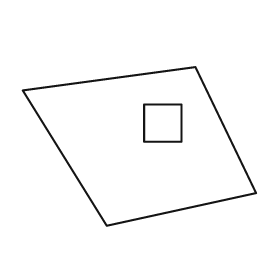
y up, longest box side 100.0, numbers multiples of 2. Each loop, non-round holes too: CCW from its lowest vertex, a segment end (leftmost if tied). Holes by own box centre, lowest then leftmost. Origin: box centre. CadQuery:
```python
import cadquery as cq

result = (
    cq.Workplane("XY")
    .moveTo(-14.0, -34.0)
    .lineTo(50.0, -20.0)
    .lineTo(24.0, 34.0)
    .lineTo(-50.0, 24.0)
    .close()
    .moveTo(2.0, 2.0)
    .lineTo(18.0, 2.0)
    .lineTo(18.0, 18.0)
    .lineTo(2.0, 18.0)
    .close()
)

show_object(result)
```